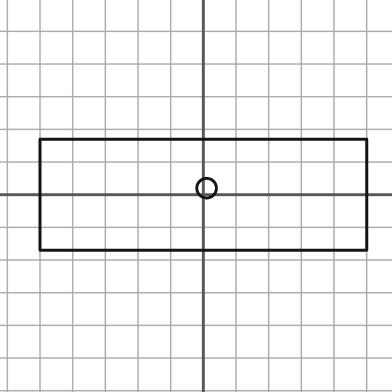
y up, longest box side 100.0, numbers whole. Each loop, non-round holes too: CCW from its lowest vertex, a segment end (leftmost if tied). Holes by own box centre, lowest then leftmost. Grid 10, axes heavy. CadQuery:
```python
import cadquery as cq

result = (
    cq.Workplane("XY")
    .moveTo(-50.0, -17.0)
    .lineTo(50.0, -17.0)
    .lineTo(50.0, 17.0)
    .lineTo(-50.0, 17.0)
    .close()
    .moveTo(1.0, 2.0)
    .circle(3.0)
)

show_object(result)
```